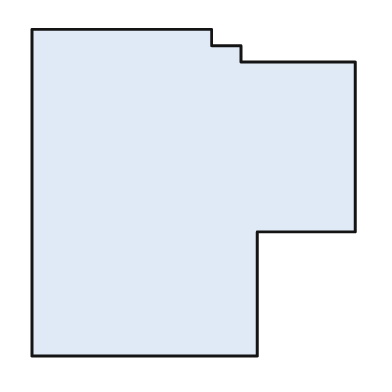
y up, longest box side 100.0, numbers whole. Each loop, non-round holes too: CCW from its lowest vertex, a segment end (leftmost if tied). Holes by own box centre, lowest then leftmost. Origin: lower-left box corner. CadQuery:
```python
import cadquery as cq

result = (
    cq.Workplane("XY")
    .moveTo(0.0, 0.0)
    .lineTo(69.0, 0.0)
    .lineTo(69.0, 38.0)
    .lineTo(99.0, 38.0)
    .lineTo(99.0, 90.0)
    .lineTo(64.0, 90.0)
    .lineTo(64.0, 95.0)
    .lineTo(55.0, 95.0)
    .lineTo(55.0, 100.0)
    .lineTo(0.0, 100.0)
    .close()
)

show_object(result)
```